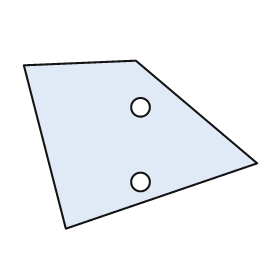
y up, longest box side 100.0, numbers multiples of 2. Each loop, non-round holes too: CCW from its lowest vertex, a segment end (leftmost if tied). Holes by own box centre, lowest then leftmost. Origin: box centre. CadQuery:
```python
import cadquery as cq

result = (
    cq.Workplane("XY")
    .moveTo(-32.0, -36.0)
    .lineTo(50.0, -8.0)
    .lineTo(-2.0, 36.0)
    .lineTo(-50.0, 34.0)
    .close()
    .moveTo(0.0, -16.0)
    .circle(4.0)
    .moveTo(0.0, 16.0)
    .circle(4.0)
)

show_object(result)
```